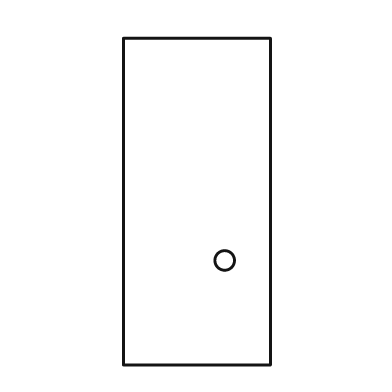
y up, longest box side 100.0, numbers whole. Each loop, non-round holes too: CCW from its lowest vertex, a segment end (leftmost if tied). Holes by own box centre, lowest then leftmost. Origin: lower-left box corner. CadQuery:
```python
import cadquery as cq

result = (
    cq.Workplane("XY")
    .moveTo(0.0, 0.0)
    .lineTo(45.0, 0.0)
    .lineTo(45.0, 100.0)
    .lineTo(0.0, 100.0)
    .close()
    .moveTo(31.0, 32.0)
    .circle(3.0)
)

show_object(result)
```